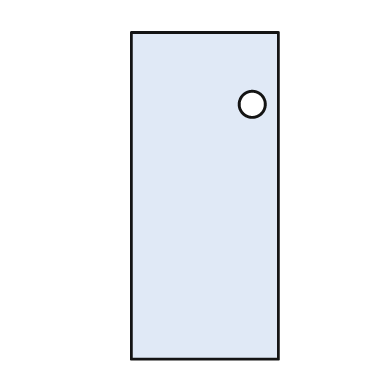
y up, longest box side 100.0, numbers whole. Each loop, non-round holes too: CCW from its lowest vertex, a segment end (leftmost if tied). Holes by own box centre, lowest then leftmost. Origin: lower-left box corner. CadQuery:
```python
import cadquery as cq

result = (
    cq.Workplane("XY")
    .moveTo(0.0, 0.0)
    .lineTo(45.0, 0.0)
    .lineTo(45.0, 100.0)
    .lineTo(0.0, 100.0)
    .close()
    .moveTo(37.0, 78.0)
    .circle(4.0)
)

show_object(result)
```